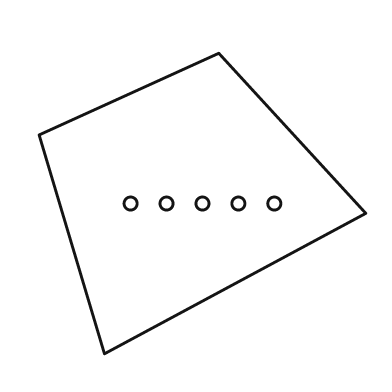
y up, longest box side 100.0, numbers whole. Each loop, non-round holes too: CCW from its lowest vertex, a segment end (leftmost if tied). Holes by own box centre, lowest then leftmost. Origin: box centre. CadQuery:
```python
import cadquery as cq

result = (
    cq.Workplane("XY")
    .moveTo(-30.0, -46.0)
    .lineTo(50.0, -3.0)
    .lineTo(5.0, 46.0)
    .lineTo(-50.0, 21.0)
    .close()
    .moveTo(-22.0, 0.0)
    .circle(2.0)
    .moveTo(-11.0, 0.0)
    .circle(2.0)
    .moveTo(0.0, 0.0)
    .circle(2.0)
    .moveTo(11.0, 0.0)
    .circle(2.0)
    .moveTo(22.0, 0.0)
    .circle(2.0)
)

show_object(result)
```